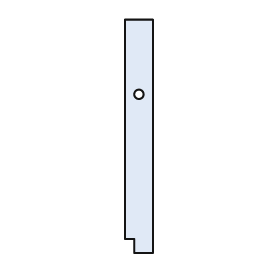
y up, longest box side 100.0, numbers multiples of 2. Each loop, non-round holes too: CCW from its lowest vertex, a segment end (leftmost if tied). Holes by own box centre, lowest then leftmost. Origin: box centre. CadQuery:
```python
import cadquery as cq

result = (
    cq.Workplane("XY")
    .moveTo(-2.0, -50.0)
    .lineTo(6.0, -50.0)
    .lineTo(6.0, 50.0)
    .lineTo(-6.0, 50.0)
    .lineTo(-6.0, -44.0)
    .lineTo(-2.0, -44.0)
    .close()
    .moveTo(0.0, 18.0)
    .circle(2.0)
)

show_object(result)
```